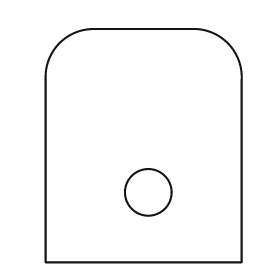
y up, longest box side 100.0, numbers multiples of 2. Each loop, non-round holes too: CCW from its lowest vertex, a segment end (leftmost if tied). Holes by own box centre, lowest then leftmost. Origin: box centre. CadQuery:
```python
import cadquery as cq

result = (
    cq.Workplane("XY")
    .moveTo(-42.0, -50.0)
    .lineTo(42.0, -50.0)
    .lineTo(42.0, 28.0)
    .threePointArc((36.0, 44.0), (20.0, 50.0))
    .lineTo(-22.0, 50.0)
    .threePointArc((-36.0, 44.0), (-42.0, 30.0))
    .close()
    .moveTo(2.0, -20.0)
    .circle(10.0)
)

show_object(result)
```